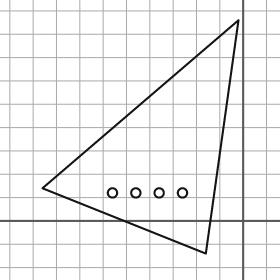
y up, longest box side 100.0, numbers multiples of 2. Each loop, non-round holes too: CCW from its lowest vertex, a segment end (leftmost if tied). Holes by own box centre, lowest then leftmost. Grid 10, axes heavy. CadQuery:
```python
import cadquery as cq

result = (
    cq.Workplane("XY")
    .moveTo(-16.0, -14.0)
    .lineTo(-2.0, 86.0)
    .lineTo(-86.0, 14.0)
    .close()
    .moveTo(-56.0, 12.0)
    .circle(2.0)
    .moveTo(-46.0, 12.0)
    .circle(2.0)
    .moveTo(-36.0, 12.0)
    .circle(2.0)
    .moveTo(-26.0, 12.0)
    .circle(2.0)
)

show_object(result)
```